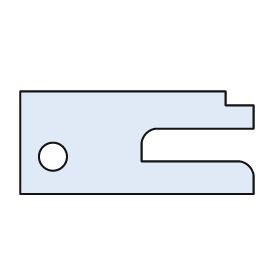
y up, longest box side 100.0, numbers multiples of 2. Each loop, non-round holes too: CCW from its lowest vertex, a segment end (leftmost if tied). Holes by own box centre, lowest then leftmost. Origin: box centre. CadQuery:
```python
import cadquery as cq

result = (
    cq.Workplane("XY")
    .moveTo(-50.0, -22.0)
    .lineTo(50.0, -22.0)
    .lineTo(50.0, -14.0)
    .threePointArc((48.0, -10.0), (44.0, -8.0))
    .lineTo(2.0, -8.0)
    .lineTo(2.0, 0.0)
    .threePointArc((4.0, 4.0), (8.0, 6.0))
    .lineTo(50.0, 6.0)
    .lineTo(50.0, 16.0)
    .lineTo(38.0, 16.0)
    .lineTo(38.0, 22.0)
    .lineTo(-50.0, 22.0)
    .close()
    .moveTo(-36.0, -6.0)
    .circle(6.0)
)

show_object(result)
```